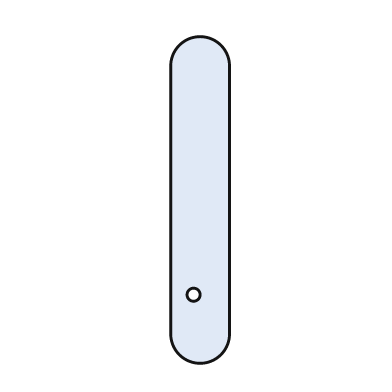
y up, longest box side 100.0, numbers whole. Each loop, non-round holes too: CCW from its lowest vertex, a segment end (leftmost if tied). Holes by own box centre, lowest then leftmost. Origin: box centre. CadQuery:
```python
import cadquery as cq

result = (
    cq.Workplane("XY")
    .moveTo(-9.0, -41.0)
    .threePointArc((0.0, -50.0), (9.0, -41.0))
    .lineTo(9.0, 41.0)
    .threePointArc((0.0, 50.0), (-9.0, 41.0))
    .close()
    .moveTo(-2.0, -29.0)
    .circle(2.0)
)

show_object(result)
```